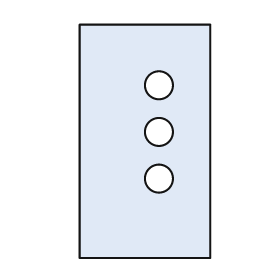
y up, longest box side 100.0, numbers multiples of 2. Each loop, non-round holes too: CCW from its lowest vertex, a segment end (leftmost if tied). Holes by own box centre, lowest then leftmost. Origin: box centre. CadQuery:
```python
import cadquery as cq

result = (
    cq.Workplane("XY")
    .moveTo(-28.0, -50.0)
    .lineTo(28.0, -50.0)
    .lineTo(28.0, 50.0)
    .lineTo(-28.0, 50.0)
    .close()
    .moveTo(6.0, -16.0)
    .circle(6.0)
    .moveTo(6.0, 4.0)
    .circle(6.0)
    .moveTo(6.0, 24.0)
    .circle(6.0)
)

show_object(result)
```